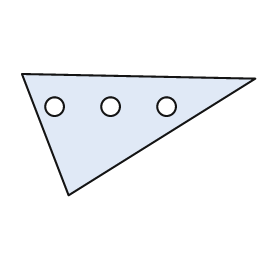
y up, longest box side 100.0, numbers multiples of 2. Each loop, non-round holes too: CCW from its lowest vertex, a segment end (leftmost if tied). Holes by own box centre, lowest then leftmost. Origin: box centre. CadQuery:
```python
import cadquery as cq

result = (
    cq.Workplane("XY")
    .moveTo(-30.0, -26.0)
    .lineTo(50.0, 24.0)
    .lineTo(-50.0, 26.0)
    .close()
    .moveTo(-36.0, 12.0)
    .circle(4.0)
    .moveTo(-12.0, 12.0)
    .circle(4.0)
    .moveTo(12.0, 12.0)
    .circle(4.0)
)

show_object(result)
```